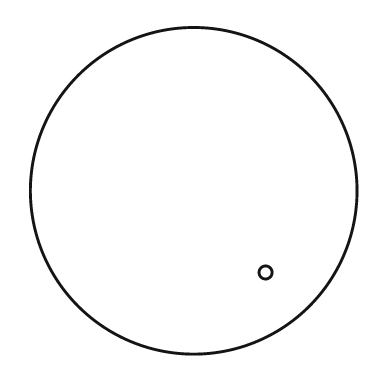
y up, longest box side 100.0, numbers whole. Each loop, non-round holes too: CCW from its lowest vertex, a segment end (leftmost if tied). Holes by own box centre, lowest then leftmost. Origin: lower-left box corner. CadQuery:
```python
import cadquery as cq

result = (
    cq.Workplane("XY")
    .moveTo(50.0, 50.0)
    .circle(50.0)
    .moveTo(72.0, 25.0)
    .circle(2.0)
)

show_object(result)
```